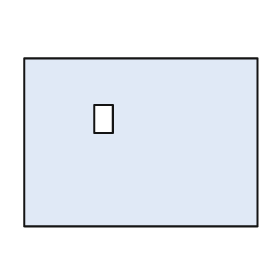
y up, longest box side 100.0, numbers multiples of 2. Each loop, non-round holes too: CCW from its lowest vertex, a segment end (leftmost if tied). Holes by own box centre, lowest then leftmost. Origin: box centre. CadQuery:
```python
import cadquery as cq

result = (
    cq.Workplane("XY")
    .moveTo(-50.0, -36.0)
    .lineTo(50.0, -36.0)
    .lineTo(50.0, 36.0)
    .lineTo(-50.0, 36.0)
    .close()
    .moveTo(-20.0, 4.0)
    .lineTo(-12.0, 4.0)
    .lineTo(-12.0, 16.0)
    .lineTo(-20.0, 16.0)
    .close()
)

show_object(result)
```